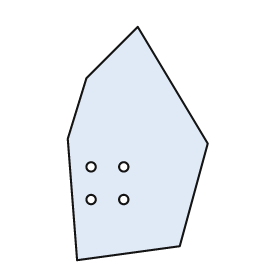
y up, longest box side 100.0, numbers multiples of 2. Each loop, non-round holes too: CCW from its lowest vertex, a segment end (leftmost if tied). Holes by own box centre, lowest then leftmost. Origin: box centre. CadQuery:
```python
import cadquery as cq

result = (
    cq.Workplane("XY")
    .moveTo(-26.0, -50.0)
    .lineTo(18.0, -44.0)
    .lineTo(30.0, 0.0)
    .lineTo(0.0, 50.0)
    .lineTo(-22.0, 28.0)
    .lineTo(-30.0, 2.0)
    .close()
    .moveTo(-20.0, -24.0)
    .circle(2.0)
    .moveTo(-6.0, -24.0)
    .circle(2.0)
    .moveTo(-20.0, -10.0)
    .circle(2.0)
    .moveTo(-6.0, -10.0)
    .circle(2.0)
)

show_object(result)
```